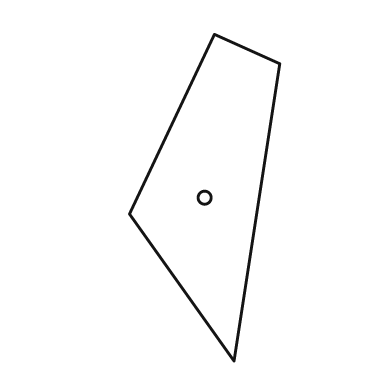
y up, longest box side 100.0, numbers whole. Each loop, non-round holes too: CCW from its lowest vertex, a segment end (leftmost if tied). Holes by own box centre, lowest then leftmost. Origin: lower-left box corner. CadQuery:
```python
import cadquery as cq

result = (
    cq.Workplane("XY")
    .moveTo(32.0, 0.0)
    .lineTo(46.0, 91.0)
    .lineTo(26.0, 100.0)
    .lineTo(0.0, 45.0)
    .close()
    .moveTo(23.0, 50.0)
    .circle(2.0)
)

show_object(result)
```